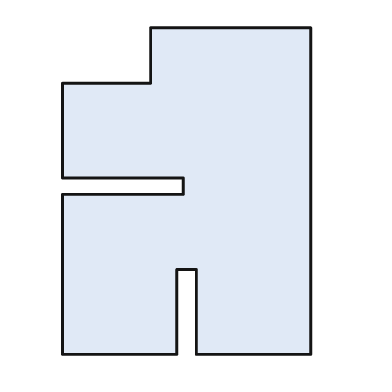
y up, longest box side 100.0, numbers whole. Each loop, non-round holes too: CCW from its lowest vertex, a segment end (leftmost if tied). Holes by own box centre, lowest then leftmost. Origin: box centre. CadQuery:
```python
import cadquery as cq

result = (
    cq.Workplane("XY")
    .moveTo(-38.0, -50.0)
    .lineTo(-3.0, -50.0)
    .lineTo(-3.0, -24.0)
    .lineTo(3.0, -24.0)
    .lineTo(3.0, -50.0)
    .lineTo(38.0, -50.0)
    .lineTo(38.0, 50.0)
    .lineTo(-11.0, 50.0)
    .lineTo(-11.0, 33.0)
    .lineTo(-38.0, 33.0)
    .lineTo(-38.0, 4.0)
    .lineTo(-1.0, 4.0)
    .lineTo(-1.0, -1.0)
    .lineTo(-38.0, -1.0)
    .close()
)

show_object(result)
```